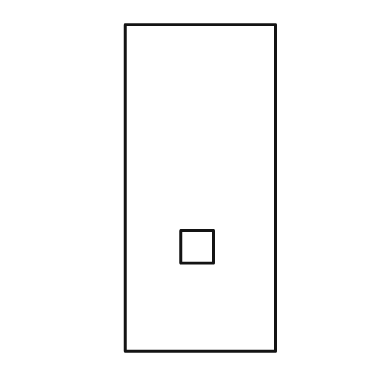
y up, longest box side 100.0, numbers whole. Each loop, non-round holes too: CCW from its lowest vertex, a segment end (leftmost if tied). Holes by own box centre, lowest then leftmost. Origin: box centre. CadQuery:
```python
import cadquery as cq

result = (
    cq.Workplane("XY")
    .moveTo(-23.0, -50.0)
    .lineTo(23.0, -50.0)
    .lineTo(23.0, 50.0)
    .lineTo(-23.0, 50.0)
    .close()
    .moveTo(-6.0, -23.0)
    .lineTo(4.0, -23.0)
    .lineTo(4.0, -13.0)
    .lineTo(-6.0, -13.0)
    .close()
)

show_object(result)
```